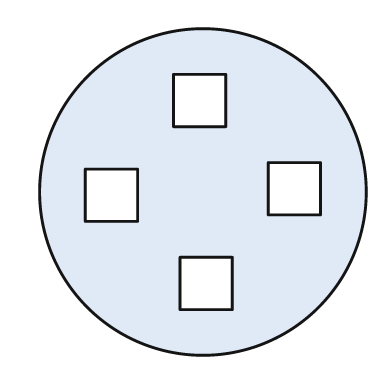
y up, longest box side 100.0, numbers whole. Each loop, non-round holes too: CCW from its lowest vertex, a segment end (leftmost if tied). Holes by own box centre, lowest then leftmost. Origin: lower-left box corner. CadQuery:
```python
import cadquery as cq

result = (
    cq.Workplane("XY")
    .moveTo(50.0, 50.0)
    .circle(50.0)
    .moveTo(43.0, 14.0)
    .lineTo(59.0, 14.0)
    .lineTo(59.0, 30.0)
    .lineTo(43.0, 30.0)
    .close()
    .moveTo(14.0, 41.0)
    .lineTo(30.0, 41.0)
    .lineTo(30.0, 57.0)
    .lineTo(14.0, 57.0)
    .close()
    .moveTo(70.0, 43.0)
    .lineTo(86.0, 43.0)
    .lineTo(86.0, 59.0)
    .lineTo(70.0, 59.0)
    .close()
    .moveTo(41.0, 70.0)
    .lineTo(57.0, 70.0)
    .lineTo(57.0, 86.0)
    .lineTo(41.0, 86.0)
    .close()
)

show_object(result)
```